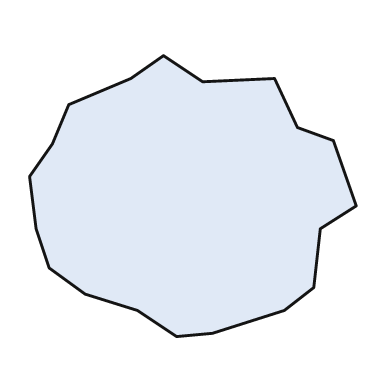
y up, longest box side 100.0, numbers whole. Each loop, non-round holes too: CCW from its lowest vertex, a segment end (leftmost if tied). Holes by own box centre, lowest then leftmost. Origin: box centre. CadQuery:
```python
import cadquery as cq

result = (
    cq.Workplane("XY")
    .moveTo(-5.0, -43.0)
    .lineTo(6.0, -42.0)
    .lineTo(28.0, -35.0)
    .lineTo(37.0, -28.0)
    .lineTo(39.0, -10.0)
    .lineTo(50.0, -3.0)
    .lineTo(43.0, 17.0)
    .lineTo(32.0, 21.0)
    .lineTo(25.0, 36.0)
    .lineTo(3.0, 35.0)
    .lineTo(-9.0, 43.0)
    .lineTo(-19.0, 36.0)
    .lineTo(-38.0, 28.0)
    .lineTo(-43.0, 16.0)
    .lineTo(-50.0, 6.0)
    .lineTo(-48.0, -10.0)
    .lineTo(-44.0, -22.0)
    .lineTo(-33.0, -30.0)
    .lineTo(-17.0, -35.0)
    .close()
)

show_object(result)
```